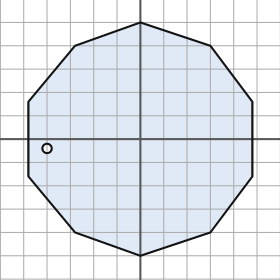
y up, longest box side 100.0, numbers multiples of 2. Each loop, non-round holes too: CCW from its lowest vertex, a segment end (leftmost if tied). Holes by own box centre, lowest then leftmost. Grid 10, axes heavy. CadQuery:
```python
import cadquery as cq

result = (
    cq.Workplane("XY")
    .moveTo(0.0, -50.0)
    .lineTo(30.0, -40.0)
    .lineTo(48.0, -16.0)
    .lineTo(48.0, 16.0)
    .lineTo(30.0, 40.0)
    .lineTo(0.0, 50.0)
    .lineTo(-28.0, 40.0)
    .lineTo(-48.0, 16.0)
    .lineTo(-48.0, -16.0)
    .lineTo(-28.0, -40.0)
    .close()
    .moveTo(-40.0, -4.0)
    .circle(2.0)
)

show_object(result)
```